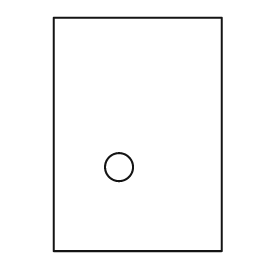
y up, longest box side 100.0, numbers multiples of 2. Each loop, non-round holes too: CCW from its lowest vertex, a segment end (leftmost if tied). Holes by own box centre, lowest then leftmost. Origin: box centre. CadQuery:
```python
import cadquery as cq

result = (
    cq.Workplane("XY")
    .moveTo(-36.0, -50.0)
    .lineTo(36.0, -50.0)
    .lineTo(36.0, 50.0)
    .lineTo(-36.0, 50.0)
    .close()
    .moveTo(-8.0, -14.0)
    .circle(6.0)
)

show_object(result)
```